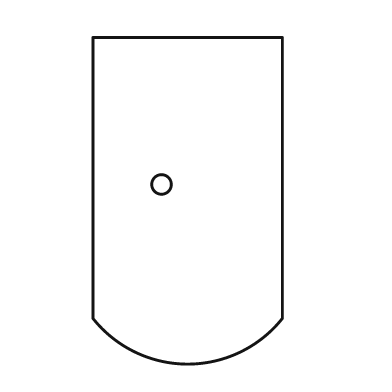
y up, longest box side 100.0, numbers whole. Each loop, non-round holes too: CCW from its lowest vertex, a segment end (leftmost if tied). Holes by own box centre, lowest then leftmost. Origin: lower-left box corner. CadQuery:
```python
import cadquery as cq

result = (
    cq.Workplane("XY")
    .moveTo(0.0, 14.0)
    .threePointArc((29.0, 0.0), (58.0, 14.0))
    .lineTo(58.0, 100.0)
    .lineTo(0.0, 100.0)
    .close()
    .moveTo(21.0, 55.0)
    .circle(3.0)
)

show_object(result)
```